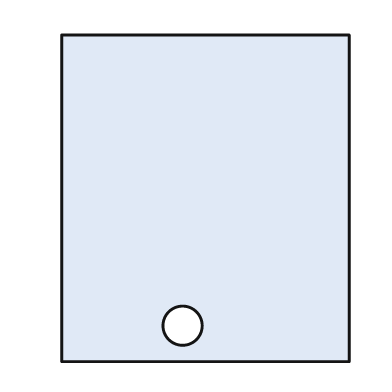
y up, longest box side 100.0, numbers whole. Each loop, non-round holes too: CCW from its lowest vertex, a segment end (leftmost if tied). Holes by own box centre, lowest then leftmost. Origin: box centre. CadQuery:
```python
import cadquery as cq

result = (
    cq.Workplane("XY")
    .moveTo(-44.0, -50.0)
    .lineTo(44.0, -50.0)
    .lineTo(44.0, 50.0)
    .lineTo(-44.0, 50.0)
    .close()
    .moveTo(-7.0, -39.0)
    .circle(6.0)
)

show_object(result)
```